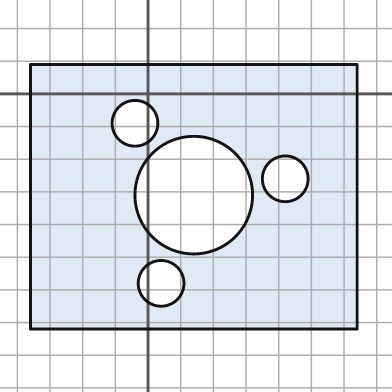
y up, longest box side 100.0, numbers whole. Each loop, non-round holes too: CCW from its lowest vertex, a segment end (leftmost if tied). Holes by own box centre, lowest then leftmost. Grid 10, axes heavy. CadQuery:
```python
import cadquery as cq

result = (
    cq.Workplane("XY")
    .moveTo(-36.0, -72.0)
    .lineTo(64.0, -72.0)
    .lineTo(64.0, 9.0)
    .lineTo(-36.0, 9.0)
    .close()
    .moveTo(4.0, -58.0)
    .circle(7.0)
    .moveTo(14.0, -31.0)
    .circle(18.0)
    .moveTo(42.0, -26.0)
    .circle(7.0)
    .moveTo(-4.0, -9.0)
    .circle(7.0)
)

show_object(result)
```